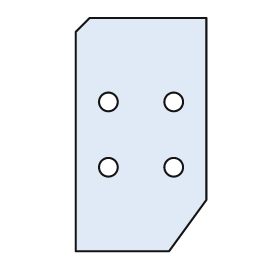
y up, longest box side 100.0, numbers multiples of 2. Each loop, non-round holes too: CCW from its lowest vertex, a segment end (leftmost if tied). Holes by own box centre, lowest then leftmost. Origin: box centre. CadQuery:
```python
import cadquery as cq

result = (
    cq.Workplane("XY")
    .moveTo(-28.0, -50.0)
    .lineTo(12.0, -50.0)
    .lineTo(28.0, -28.0)
    .lineTo(28.0, 50.0)
    .lineTo(-22.0, 50.0)
    .lineTo(-28.0, 44.0)
    .close()
    .moveTo(-14.0, -14.0)
    .circle(4.0)
    .moveTo(14.0, -14.0)
    .circle(4.0)
    .moveTo(-14.0, 14.0)
    .circle(4.0)
    .moveTo(14.0, 14.0)
    .circle(4.0)
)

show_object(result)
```